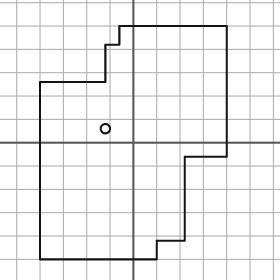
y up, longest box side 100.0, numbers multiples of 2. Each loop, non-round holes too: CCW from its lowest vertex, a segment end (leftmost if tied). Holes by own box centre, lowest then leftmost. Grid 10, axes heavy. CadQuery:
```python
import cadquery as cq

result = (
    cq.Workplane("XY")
    .moveTo(-40.0, -50.0)
    .lineTo(10.0, -50.0)
    .lineTo(10.0, -42.0)
    .lineTo(22.0, -42.0)
    .lineTo(22.0, -6.0)
    .lineTo(40.0, -6.0)
    .lineTo(40.0, 50.0)
    .lineTo(-6.0, 50.0)
    .lineTo(-6.0, 42.0)
    .lineTo(-12.0, 42.0)
    .lineTo(-12.0, 26.0)
    .lineTo(-40.0, 26.0)
    .close()
    .moveTo(-12.0, 6.0)
    .circle(2.0)
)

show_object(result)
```